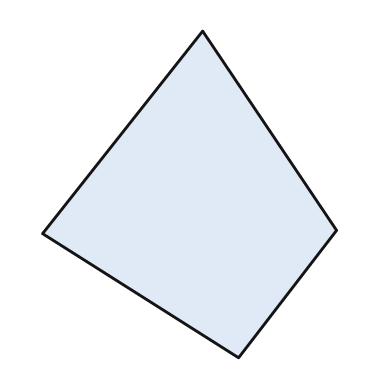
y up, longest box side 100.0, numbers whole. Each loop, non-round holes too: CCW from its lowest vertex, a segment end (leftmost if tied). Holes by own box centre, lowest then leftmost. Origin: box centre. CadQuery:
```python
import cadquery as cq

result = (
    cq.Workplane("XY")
    .moveTo(15.0, -50.0)
    .lineTo(45.0, -11.0)
    .lineTo(4.0, 50.0)
    .lineTo(-45.0, -12.0)
    .close()
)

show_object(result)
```